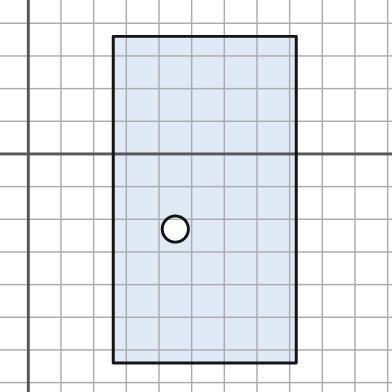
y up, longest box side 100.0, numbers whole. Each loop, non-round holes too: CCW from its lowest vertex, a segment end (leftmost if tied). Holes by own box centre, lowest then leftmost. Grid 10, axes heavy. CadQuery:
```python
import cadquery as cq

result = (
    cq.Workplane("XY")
    .moveTo(26.0, -64.0)
    .lineTo(82.0, -64.0)
    .lineTo(82.0, 36.0)
    .lineTo(26.0, 36.0)
    .close()
    .moveTo(45.0, -23.0)
    .circle(4.0)
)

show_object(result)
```